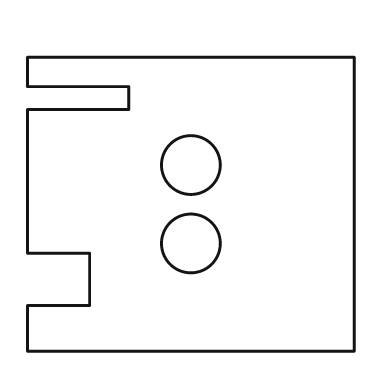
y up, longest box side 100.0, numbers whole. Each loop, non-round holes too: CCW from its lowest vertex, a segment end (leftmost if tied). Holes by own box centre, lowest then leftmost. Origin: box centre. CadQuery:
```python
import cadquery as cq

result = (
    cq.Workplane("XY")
    .moveTo(-50.0, -45.0)
    .lineTo(50.0, -45.0)
    .lineTo(50.0, 45.0)
    .lineTo(-50.0, 45.0)
    .lineTo(-50.0, 36.0)
    .lineTo(-19.0, 36.0)
    .lineTo(-19.0, 29.0)
    .lineTo(-50.0, 29.0)
    .lineTo(-50.0, -15.0)
    .lineTo(-31.0, -15.0)
    .lineTo(-31.0, -31.0)
    .lineTo(-50.0, -31.0)
    .close()
    .moveTo(0.0, -12.0)
    .circle(9.0)
    .moveTo(0.0, 12.0)
    .circle(9.0)
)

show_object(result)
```